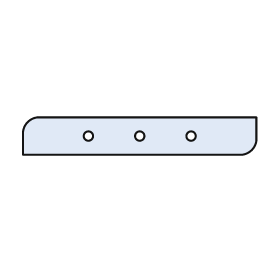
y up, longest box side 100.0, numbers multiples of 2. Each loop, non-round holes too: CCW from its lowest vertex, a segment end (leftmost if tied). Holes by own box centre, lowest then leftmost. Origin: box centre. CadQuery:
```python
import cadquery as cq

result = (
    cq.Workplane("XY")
    .moveTo(-50.0, -8.0)
    .lineTo(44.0, -8.0)
    .threePointArc((48.0, -6.0), (50.0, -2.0))
    .lineTo(50.0, 8.0)
    .lineTo(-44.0, 8.0)
    .threePointArc((-48.0, 6.0), (-50.0, 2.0))
    .close()
    .moveTo(-22.0, 0.0)
    .circle(2.0)
    .moveTo(0.0, 0.0)
    .circle(2.0)
    .moveTo(22.0, 0.0)
    .circle(2.0)
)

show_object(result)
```